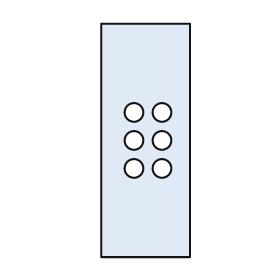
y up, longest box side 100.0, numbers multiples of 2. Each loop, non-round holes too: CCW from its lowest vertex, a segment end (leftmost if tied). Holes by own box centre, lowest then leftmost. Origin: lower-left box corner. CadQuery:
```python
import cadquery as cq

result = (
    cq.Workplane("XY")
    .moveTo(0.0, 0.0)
    .lineTo(38.0, 0.0)
    .lineTo(38.0, 100.0)
    .lineTo(0.0, 100.0)
    .close()
    .moveTo(14.0, 38.0)
    .circle(4.0)
    .moveTo(26.0, 38.0)
    .circle(4.0)
    .moveTo(14.0, 50.0)
    .circle(4.0)
    .moveTo(26.0, 50.0)
    .circle(4.0)
    .moveTo(14.0, 62.0)
    .circle(4.0)
    .moveTo(26.0, 62.0)
    .circle(4.0)
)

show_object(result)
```